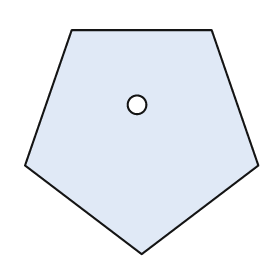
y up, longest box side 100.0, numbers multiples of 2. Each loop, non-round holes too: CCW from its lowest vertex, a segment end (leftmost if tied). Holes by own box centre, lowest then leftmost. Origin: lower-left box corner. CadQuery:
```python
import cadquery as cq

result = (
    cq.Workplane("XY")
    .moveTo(50.0, 0.0)
    .lineTo(100.0, 38.0)
    .lineTo(80.0, 96.0)
    .lineTo(20.0, 96.0)
    .lineTo(0.0, 38.0)
    .close()
    .moveTo(48.0, 64.0)
    .circle(4.0)
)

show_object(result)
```